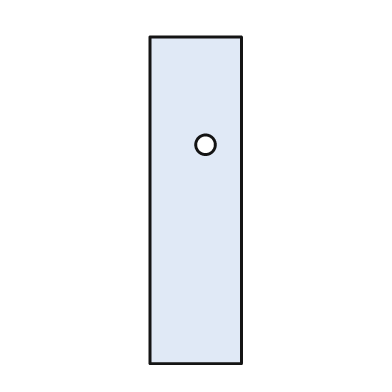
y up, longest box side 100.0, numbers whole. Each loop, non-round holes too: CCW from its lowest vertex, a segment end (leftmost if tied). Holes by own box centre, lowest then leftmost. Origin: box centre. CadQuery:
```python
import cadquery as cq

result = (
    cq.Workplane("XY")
    .moveTo(-14.0, -50.0)
    .lineTo(14.0, -50.0)
    .lineTo(14.0, 50.0)
    .lineTo(-14.0, 50.0)
    .close()
    .moveTo(3.0, 17.0)
    .circle(3.0)
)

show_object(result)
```